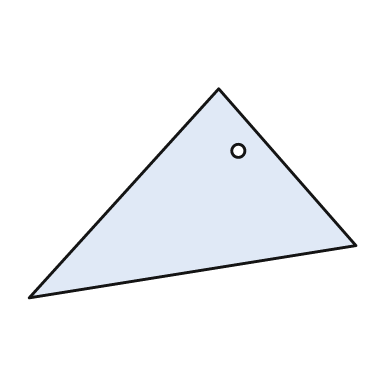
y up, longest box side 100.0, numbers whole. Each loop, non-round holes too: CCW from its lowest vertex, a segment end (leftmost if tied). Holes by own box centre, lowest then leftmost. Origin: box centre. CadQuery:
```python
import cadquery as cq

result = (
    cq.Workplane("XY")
    .moveTo(-50.0, -32.0)
    .lineTo(50.0, -16.0)
    .lineTo(8.0, 32.0)
    .close()
    .moveTo(14.0, 13.0)
    .circle(2.0)
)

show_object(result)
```